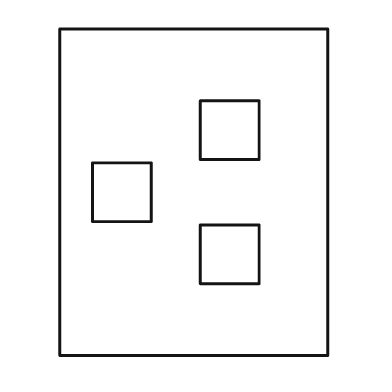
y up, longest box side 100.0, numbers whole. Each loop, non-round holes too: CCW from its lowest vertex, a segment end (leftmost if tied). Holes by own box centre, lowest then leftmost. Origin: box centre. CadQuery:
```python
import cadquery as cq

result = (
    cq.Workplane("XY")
    .moveTo(-41.0, -50.0)
    .lineTo(41.0, -50.0)
    .lineTo(41.0, 50.0)
    .lineTo(-41.0, 50.0)
    .close()
    .moveTo(2.0, -28.0)
    .lineTo(20.0, -28.0)
    .lineTo(20.0, -10.0)
    .lineTo(2.0, -10.0)
    .close()
    .moveTo(-31.0, -9.0)
    .lineTo(-13.0, -9.0)
    .lineTo(-13.0, 9.0)
    .lineTo(-31.0, 9.0)
    .close()
    .moveTo(2.0, 10.0)
    .lineTo(20.0, 10.0)
    .lineTo(20.0, 28.0)
    .lineTo(2.0, 28.0)
    .close()
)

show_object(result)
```